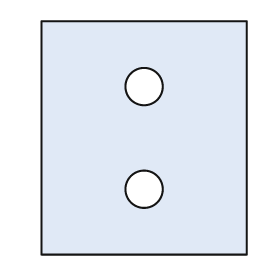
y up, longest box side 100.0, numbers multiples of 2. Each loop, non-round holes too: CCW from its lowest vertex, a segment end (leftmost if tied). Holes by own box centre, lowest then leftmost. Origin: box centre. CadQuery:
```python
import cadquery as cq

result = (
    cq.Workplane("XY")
    .moveTo(-44.0, -50.0)
    .lineTo(44.0, -50.0)
    .lineTo(44.0, 50.0)
    .lineTo(-44.0, 50.0)
    .close()
    .moveTo(0.0, -22.0)
    .circle(8.0)
    .moveTo(0.0, 22.0)
    .circle(8.0)
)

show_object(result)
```